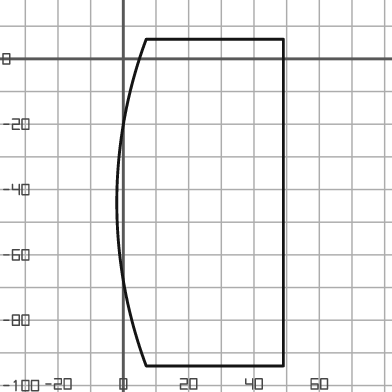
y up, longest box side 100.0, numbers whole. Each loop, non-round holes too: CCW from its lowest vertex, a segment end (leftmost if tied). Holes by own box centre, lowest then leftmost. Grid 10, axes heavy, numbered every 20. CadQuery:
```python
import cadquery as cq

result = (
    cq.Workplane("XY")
    .moveTo(7.0, -94.0)
    .lineTo(49.0, -94.0)
    .lineTo(49.0, 6.0)
    .lineTo(7.0, 6.0)
    .threePointArc((-2.0, -44.0), (7.0, -94.0))
    .close()
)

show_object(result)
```